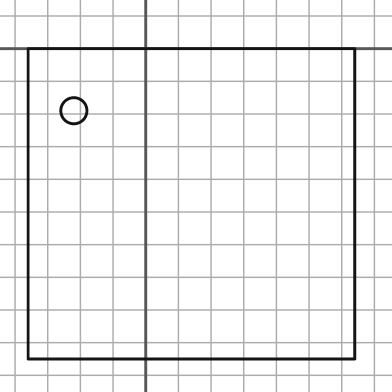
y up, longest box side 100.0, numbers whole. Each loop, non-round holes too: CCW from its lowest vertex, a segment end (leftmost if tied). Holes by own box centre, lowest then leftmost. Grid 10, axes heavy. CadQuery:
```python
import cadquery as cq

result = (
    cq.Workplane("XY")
    .moveTo(-36.0, -95.0)
    .lineTo(64.0, -95.0)
    .lineTo(64.0, 0.0)
    .lineTo(-36.0, 0.0)
    .close()
    .moveTo(-22.0, -19.0)
    .circle(4.0)
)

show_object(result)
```